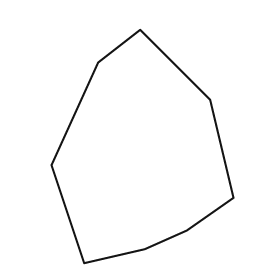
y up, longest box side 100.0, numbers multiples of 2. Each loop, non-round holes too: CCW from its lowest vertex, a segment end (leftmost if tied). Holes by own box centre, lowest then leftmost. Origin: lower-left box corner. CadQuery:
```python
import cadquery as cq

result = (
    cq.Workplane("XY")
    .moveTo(14.0, 0.0)
    .lineTo(40.0, 6.0)
    .lineTo(58.0, 14.0)
    .lineTo(78.0, 28.0)
    .lineTo(68.0, 70.0)
    .lineTo(38.0, 100.0)
    .lineTo(20.0, 86.0)
    .lineTo(0.0, 42.0)
    .close()
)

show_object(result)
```